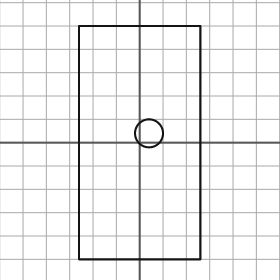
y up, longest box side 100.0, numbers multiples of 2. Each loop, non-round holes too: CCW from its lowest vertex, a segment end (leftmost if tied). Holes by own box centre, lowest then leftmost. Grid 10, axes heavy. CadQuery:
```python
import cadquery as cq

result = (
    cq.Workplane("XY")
    .moveTo(-26.0, -50.0)
    .lineTo(26.0, -50.0)
    .lineTo(26.0, 50.0)
    .lineTo(-26.0, 50.0)
    .close()
    .moveTo(4.0, 4.0)
    .circle(6.0)
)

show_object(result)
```